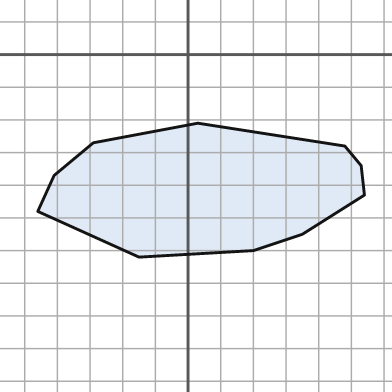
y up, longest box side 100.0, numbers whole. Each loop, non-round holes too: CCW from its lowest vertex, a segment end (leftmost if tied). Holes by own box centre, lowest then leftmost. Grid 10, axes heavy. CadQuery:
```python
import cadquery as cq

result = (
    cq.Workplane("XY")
    .moveTo(-15.0, -62.0)
    .lineTo(20.0, -60.0)
    .lineTo(35.0, -55.0)
    .lineTo(54.0, -43.0)
    .lineTo(53.0, -34.0)
    .lineTo(48.0, -28.0)
    .lineTo(3.0, -21.0)
    .lineTo(-29.0, -27.0)
    .lineTo(-41.0, -37.0)
    .lineTo(-46.0, -48.0)
    .close()
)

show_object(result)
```